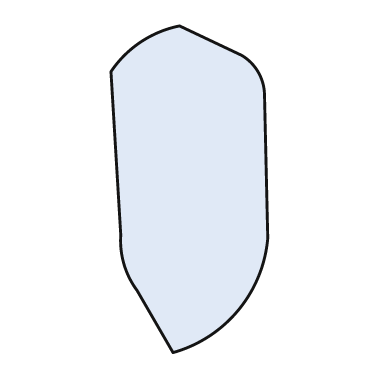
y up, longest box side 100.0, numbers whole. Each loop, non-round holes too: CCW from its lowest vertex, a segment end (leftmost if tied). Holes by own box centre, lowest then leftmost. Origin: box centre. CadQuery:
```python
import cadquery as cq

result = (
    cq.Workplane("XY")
    .moveTo(-5.0, -50.0)
    .threePointArc((15.0, -37.0), (24.0, -15.0))
    .lineTo(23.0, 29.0)
    .threePointArc((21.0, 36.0), (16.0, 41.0))
    .lineTo(-3.0, 50.0)
    .threePointArc((-15.0, 45.0), (-24.0, 36.0))
    .lineTo(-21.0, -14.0)
    .threePointArc((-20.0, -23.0), (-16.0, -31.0))
    .close()
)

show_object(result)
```